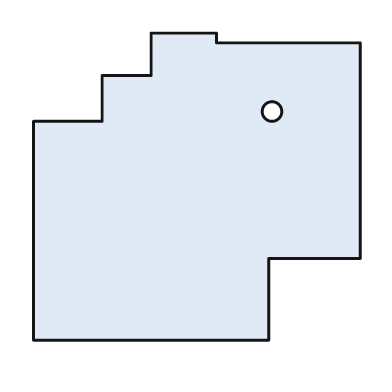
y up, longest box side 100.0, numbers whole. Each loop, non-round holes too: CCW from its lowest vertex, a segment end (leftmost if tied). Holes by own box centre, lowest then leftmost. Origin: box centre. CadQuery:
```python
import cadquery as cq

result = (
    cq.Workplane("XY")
    .moveTo(-50.0, -47.0)
    .lineTo(22.0, -47.0)
    .lineTo(22.0, -22.0)
    .lineTo(50.0, -22.0)
    .lineTo(50.0, 44.0)
    .lineTo(6.0, 44.0)
    .lineTo(6.0, 47.0)
    .lineTo(-14.0, 47.0)
    .lineTo(-14.0, 34.0)
    .lineTo(-29.0, 34.0)
    .lineTo(-29.0, 20.0)
    .lineTo(-50.0, 20.0)
    .close()
    .moveTo(23.0, 23.0)
    .circle(3.0)
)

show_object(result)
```